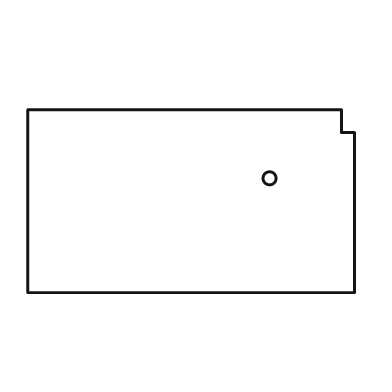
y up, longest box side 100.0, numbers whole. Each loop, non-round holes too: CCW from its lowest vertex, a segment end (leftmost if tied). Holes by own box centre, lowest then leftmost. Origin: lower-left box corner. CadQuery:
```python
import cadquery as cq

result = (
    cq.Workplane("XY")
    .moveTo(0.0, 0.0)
    .lineTo(100.0, 0.0)
    .lineTo(100.0, 49.0)
    .lineTo(96.0, 49.0)
    .lineTo(96.0, 56.0)
    .lineTo(0.0, 56.0)
    .close()
    .moveTo(74.0, 35.0)
    .circle(2.0)
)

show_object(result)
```